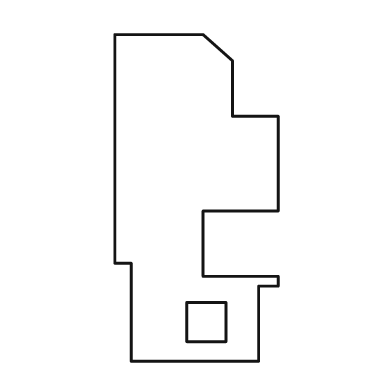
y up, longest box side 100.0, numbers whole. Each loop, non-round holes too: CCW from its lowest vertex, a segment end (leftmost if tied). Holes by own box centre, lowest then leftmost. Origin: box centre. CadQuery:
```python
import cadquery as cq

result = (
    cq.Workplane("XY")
    .moveTo(-20.0, -50.0)
    .lineTo(19.0, -50.0)
    .lineTo(19.0, -27.0)
    .lineTo(25.0, -27.0)
    .lineTo(25.0, -24.0)
    .lineTo(2.0, -24.0)
    .lineTo(2.0, -4.0)
    .lineTo(25.0, -4.0)
    .lineTo(25.0, 25.0)
    .lineTo(11.0, 25.0)
    .lineTo(11.0, 42.0)
    .lineTo(2.0, 50.0)
    .lineTo(-25.0, 50.0)
    .lineTo(-25.0, -20.0)
    .lineTo(-20.0, -20.0)
    .close()
    .moveTo(-3.0, -44.0)
    .lineTo(9.0, -44.0)
    .lineTo(9.0, -32.0)
    .lineTo(-3.0, -32.0)
    .close()
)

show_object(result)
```